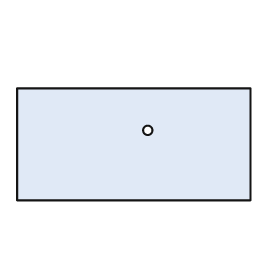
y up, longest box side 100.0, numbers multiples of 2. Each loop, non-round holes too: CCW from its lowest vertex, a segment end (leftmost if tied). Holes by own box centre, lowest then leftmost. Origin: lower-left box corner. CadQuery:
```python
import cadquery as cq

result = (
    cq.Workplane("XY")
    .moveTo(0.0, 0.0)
    .lineTo(100.0, 0.0)
    .lineTo(100.0, 48.0)
    .lineTo(0.0, 48.0)
    .close()
    .moveTo(56.0, 30.0)
    .circle(2.0)
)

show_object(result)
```